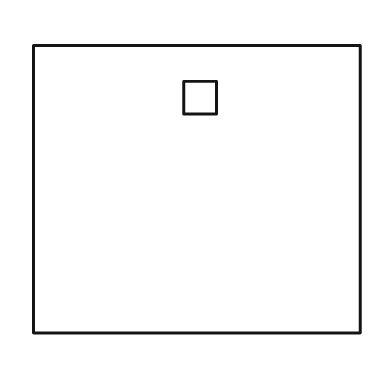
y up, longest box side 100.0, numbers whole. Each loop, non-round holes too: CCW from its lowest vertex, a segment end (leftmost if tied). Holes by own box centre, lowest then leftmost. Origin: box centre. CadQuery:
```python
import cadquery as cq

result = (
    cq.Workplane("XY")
    .moveTo(-50.0, -44.0)
    .lineTo(50.0, -44.0)
    .lineTo(50.0, 44.0)
    .lineTo(-50.0, 44.0)
    .close()
    .moveTo(-4.0, 23.0)
    .lineTo(6.0, 23.0)
    .lineTo(6.0, 33.0)
    .lineTo(-4.0, 33.0)
    .close()
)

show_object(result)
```